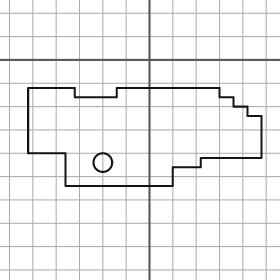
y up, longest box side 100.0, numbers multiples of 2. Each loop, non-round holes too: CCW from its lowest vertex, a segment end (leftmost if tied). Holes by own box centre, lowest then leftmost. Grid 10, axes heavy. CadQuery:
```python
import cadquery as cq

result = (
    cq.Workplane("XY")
    .moveTo(-36.0, -54.0)
    .lineTo(10.0, -54.0)
    .lineTo(10.0, -46.0)
    .lineTo(22.0, -46.0)
    .lineTo(22.0, -42.0)
    .lineTo(48.0, -42.0)
    .lineTo(48.0, -24.0)
    .lineTo(42.0, -24.0)
    .lineTo(42.0, -20.0)
    .lineTo(36.0, -20.0)
    .lineTo(36.0, -16.0)
    .lineTo(30.0, -16.0)
    .lineTo(30.0, -12.0)
    .lineTo(-14.0, -12.0)
    .lineTo(-14.0, -16.0)
    .lineTo(-32.0, -16.0)
    .lineTo(-32.0, -12.0)
    .lineTo(-52.0, -12.0)
    .lineTo(-52.0, -40.0)
    .lineTo(-36.0, -40.0)
    .close()
    .moveTo(-20.0, -44.0)
    .circle(4.0)
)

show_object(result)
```